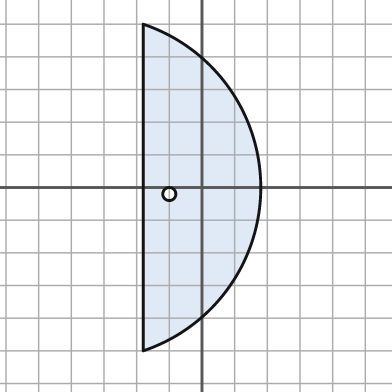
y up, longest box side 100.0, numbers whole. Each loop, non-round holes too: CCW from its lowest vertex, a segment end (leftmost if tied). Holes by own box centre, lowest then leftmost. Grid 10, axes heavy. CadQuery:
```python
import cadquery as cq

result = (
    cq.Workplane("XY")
    .moveTo(-18.0, -50.0)
    .threePointArc((18.0, 0.0), (-18.0, 50.0))
    .close()
    .moveTo(-10.0, -2.0)
    .circle(2.0)
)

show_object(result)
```